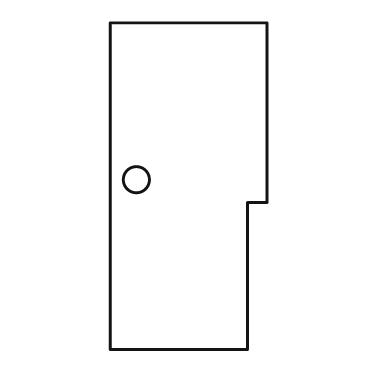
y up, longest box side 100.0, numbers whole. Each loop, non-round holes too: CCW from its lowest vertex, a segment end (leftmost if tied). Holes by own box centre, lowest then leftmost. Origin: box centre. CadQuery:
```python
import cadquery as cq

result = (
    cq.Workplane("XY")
    .moveTo(-24.0, -50.0)
    .lineTo(18.0, -50.0)
    .lineTo(18.0, -5.0)
    .lineTo(24.0, -5.0)
    .lineTo(24.0, 50.0)
    .lineTo(-24.0, 50.0)
    .close()
    .moveTo(-16.0, 2.0)
    .circle(4.0)
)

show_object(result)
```